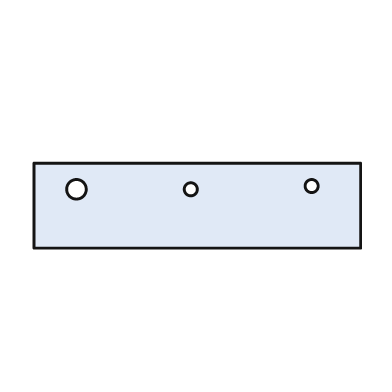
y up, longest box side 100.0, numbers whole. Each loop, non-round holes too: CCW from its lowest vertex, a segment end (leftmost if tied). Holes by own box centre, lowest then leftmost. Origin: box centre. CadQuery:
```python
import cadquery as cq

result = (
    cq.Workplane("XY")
    .moveTo(-50.0, -13.0)
    .lineTo(50.0, -13.0)
    .lineTo(50.0, 13.0)
    .lineTo(-50.0, 13.0)
    .close()
    .moveTo(-37.0, 5.0)
    .circle(3.0)
    .moveTo(-2.0, 5.0)
    .circle(2.0)
    .moveTo(35.0, 6.0)
    .circle(2.0)
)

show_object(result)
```